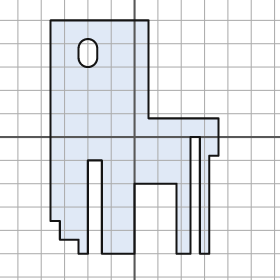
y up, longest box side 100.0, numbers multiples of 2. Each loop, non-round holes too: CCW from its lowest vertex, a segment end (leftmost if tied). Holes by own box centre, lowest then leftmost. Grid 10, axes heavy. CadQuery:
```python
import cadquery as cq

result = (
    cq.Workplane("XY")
    .moveTo(-24.0, -50.0)
    .lineTo(-20.0, -50.0)
    .lineTo(-20.0, -10.0)
    .lineTo(-14.0, -10.0)
    .lineTo(-14.0, -50.0)
    .lineTo(0.0, -50.0)
    .lineTo(0.0, -20.0)
    .lineTo(18.0, -20.0)
    .lineTo(18.0, -50.0)
    .lineTo(24.0, -50.0)
    .lineTo(24.0, 0.0)
    .lineTo(28.0, 0.0)
    .lineTo(28.0, -50.0)
    .lineTo(32.0, -50.0)
    .lineTo(32.0, -8.0)
    .lineTo(36.0, -8.0)
    .lineTo(36.0, 8.0)
    .lineTo(6.0, 8.0)
    .lineTo(6.0, 50.0)
    .lineTo(-36.0, 50.0)
    .lineTo(-36.0, -36.0)
    .lineTo(-32.0, -36.0)
    .lineTo(-32.0, -44.0)
    .lineTo(-24.0, -44.0)
    .close()
    .moveTo(-24.0, 34.0)
    .threePointArc((-20.0, 30.0), (-16.0, 34.0))
    .lineTo(-16.0, 38.0)
    .threePointArc((-20.0, 42.0), (-24.0, 38.0))
    .close()
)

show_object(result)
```